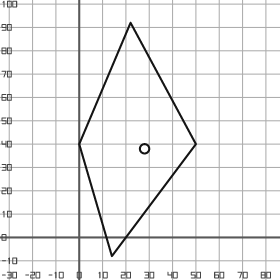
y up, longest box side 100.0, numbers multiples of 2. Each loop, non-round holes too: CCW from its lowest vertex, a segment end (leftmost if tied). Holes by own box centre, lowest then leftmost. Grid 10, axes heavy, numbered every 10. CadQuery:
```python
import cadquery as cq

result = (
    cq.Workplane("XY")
    .moveTo(14.0, -8.0)
    .lineTo(50.0, 40.0)
    .lineTo(22.0, 92.0)
    .lineTo(0.0, 40.0)
    .close()
    .moveTo(28.0, 38.0)
    .circle(2.0)
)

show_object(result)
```